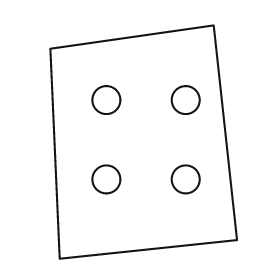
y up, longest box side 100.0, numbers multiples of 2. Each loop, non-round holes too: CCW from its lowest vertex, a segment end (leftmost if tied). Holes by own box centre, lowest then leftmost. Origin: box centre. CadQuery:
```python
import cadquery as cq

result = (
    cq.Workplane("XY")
    .moveTo(-36.0, -50.0)
    .lineTo(40.0, -42.0)
    .lineTo(30.0, 50.0)
    .lineTo(-40.0, 40.0)
    .close()
    .moveTo(-16.0, -16.0)
    .circle(6.0)
    .moveTo(18.0, -16.0)
    .circle(6.0)
    .moveTo(-16.0, 18.0)
    .circle(6.0)
    .moveTo(18.0, 18.0)
    .circle(6.0)
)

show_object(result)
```